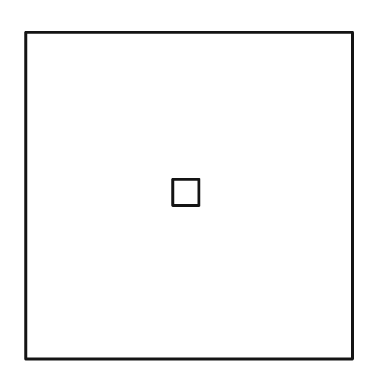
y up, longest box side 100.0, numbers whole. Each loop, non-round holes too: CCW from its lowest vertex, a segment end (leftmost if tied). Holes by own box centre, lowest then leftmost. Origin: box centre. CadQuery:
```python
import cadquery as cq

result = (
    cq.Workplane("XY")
    .moveTo(-50.0, -50.0)
    .lineTo(50.0, -50.0)
    .lineTo(50.0, 50.0)
    .lineTo(-50.0, 50.0)
    .close()
    .moveTo(-5.0, -3.0)
    .lineTo(3.0, -3.0)
    .lineTo(3.0, 5.0)
    .lineTo(-5.0, 5.0)
    .close()
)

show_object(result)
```